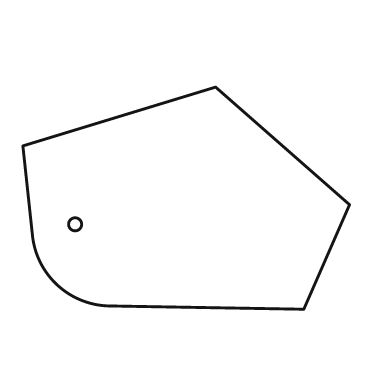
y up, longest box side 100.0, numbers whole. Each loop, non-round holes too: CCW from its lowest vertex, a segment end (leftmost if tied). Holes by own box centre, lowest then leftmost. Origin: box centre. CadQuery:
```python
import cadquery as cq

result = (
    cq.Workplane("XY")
    .moveTo(36.0, -34.0)
    .lineTo(50.0, -2.0)
    .lineTo(9.0, 34.0)
    .lineTo(-50.0, 16.0)
    .lineTo(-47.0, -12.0)
    .threePointArc((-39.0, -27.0), (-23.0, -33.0))
    .close()
    .moveTo(-34.0, -8.0)
    .circle(2.0)
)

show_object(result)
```